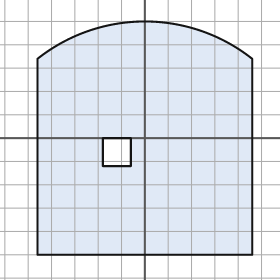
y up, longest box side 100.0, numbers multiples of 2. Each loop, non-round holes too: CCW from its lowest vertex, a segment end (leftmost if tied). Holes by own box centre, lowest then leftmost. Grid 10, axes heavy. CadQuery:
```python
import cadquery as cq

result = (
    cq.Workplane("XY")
    .moveTo(-46.0, -50.0)
    .lineTo(46.0, -50.0)
    .lineTo(46.0, 34.0)
    .threePointArc((0.0, 50.0), (-46.0, 34.0))
    .close()
    .moveTo(-18.0, -12.0)
    .lineTo(-6.0, -12.0)
    .lineTo(-6.0, 0.0)
    .lineTo(-18.0, 0.0)
    .close()
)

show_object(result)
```